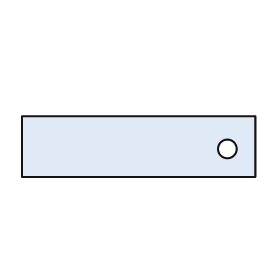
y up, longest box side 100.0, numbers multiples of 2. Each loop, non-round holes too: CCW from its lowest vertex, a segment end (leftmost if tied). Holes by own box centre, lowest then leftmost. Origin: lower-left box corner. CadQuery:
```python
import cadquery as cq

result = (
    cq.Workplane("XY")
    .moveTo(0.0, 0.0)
    .lineTo(100.0, 0.0)
    .lineTo(100.0, 26.0)
    .lineTo(0.0, 26.0)
    .close()
    .moveTo(88.0, 12.0)
    .circle(4.0)
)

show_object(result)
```